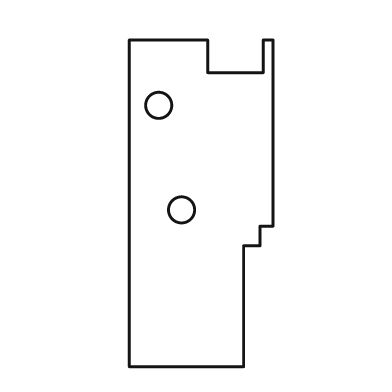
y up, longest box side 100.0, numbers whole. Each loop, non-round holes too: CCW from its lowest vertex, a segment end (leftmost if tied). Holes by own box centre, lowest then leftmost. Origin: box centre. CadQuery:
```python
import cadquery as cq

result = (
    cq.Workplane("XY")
    .moveTo(-22.0, -50.0)
    .lineTo(13.0, -50.0)
    .lineTo(13.0, -13.0)
    .lineTo(18.0, -13.0)
    .lineTo(18.0, -7.0)
    .lineTo(22.0, -7.0)
    .lineTo(22.0, 50.0)
    .lineTo(19.0, 50.0)
    .lineTo(19.0, 40.0)
    .lineTo(2.0, 40.0)
    .lineTo(2.0, 50.0)
    .lineTo(-22.0, 50.0)
    .close()
    .moveTo(-6.0, -2.0)
    .circle(4.0)
    .moveTo(-13.0, 30.0)
    .circle(4.0)
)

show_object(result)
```